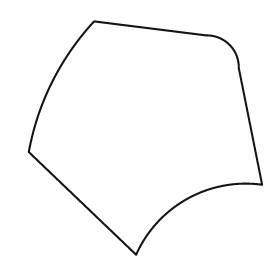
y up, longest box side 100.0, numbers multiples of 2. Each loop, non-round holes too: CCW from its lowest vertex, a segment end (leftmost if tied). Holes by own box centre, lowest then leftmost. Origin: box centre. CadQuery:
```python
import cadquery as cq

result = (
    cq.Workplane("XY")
    .moveTo(-4.0, -50.0)
    .threePointArc((18.0, -26.0), (50.0, -20.0))
    .lineTo(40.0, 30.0)
    .threePointArc((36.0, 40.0), (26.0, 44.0))
    .lineTo(-22.0, 50.0)
    .threePointArc((-40.0, 24.0), (-50.0, -6.0))
    .close()
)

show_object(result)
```